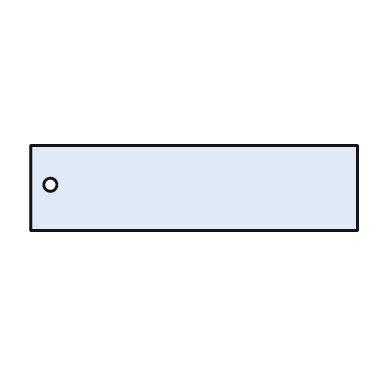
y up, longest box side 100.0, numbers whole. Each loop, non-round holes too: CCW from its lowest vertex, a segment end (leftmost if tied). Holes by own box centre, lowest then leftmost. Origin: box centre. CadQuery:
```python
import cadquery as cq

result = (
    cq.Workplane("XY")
    .moveTo(-50.0, -13.0)
    .lineTo(50.0, -13.0)
    .lineTo(50.0, 13.0)
    .lineTo(-50.0, 13.0)
    .close()
    .moveTo(-44.0, 1.0)
    .circle(2.0)
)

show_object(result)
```